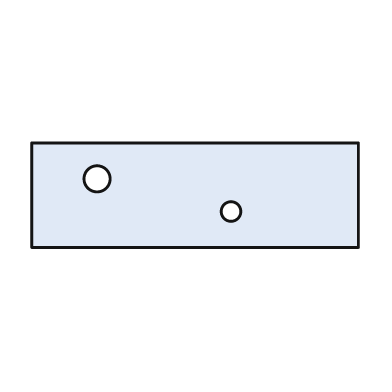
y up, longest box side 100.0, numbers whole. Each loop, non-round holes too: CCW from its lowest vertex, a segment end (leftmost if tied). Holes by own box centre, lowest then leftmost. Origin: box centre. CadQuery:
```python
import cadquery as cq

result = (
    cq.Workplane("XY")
    .moveTo(-50.0, -16.0)
    .lineTo(50.0, -16.0)
    .lineTo(50.0, 16.0)
    .lineTo(-50.0, 16.0)
    .close()
    .moveTo(11.0, -5.0)
    .circle(3.0)
    .moveTo(-30.0, 5.0)
    .circle(4.0)
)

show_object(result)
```